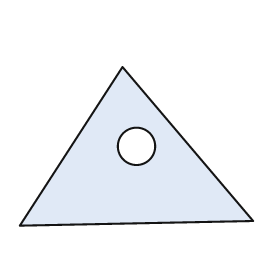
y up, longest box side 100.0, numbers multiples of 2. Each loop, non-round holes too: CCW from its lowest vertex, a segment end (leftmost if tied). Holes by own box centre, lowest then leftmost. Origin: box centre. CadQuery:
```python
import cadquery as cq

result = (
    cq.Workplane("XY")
    .moveTo(-50.0, -34.0)
    .lineTo(50.0, -32.0)
    .lineTo(-6.0, 34.0)
    .close()
    .moveTo(0.0, 0.0)
    .circle(8.0)
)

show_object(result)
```